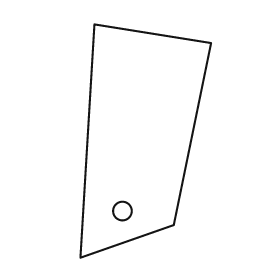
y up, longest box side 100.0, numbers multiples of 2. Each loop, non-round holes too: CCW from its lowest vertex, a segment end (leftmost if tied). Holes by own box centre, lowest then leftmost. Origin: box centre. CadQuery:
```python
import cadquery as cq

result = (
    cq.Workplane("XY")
    .moveTo(-28.0, -50.0)
    .lineTo(12.0, -36.0)
    .lineTo(28.0, 42.0)
    .lineTo(-22.0, 50.0)
    .close()
    .moveTo(-10.0, -30.0)
    .circle(4.0)
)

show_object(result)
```